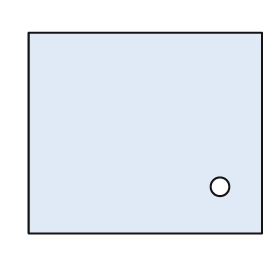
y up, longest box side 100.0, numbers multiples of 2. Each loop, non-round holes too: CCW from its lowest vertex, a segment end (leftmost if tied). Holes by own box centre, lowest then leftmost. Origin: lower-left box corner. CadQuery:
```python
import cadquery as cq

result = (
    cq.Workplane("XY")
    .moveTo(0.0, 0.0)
    .lineTo(100.0, 0.0)
    .lineTo(100.0, 86.0)
    .lineTo(0.0, 86.0)
    .close()
    .moveTo(82.0, 20.0)
    .circle(4.0)
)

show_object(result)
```